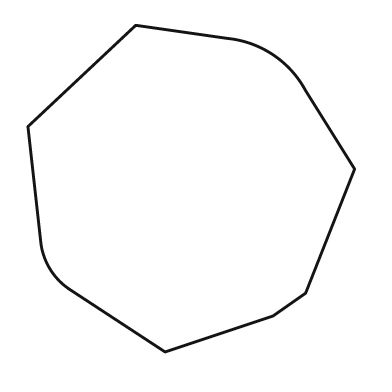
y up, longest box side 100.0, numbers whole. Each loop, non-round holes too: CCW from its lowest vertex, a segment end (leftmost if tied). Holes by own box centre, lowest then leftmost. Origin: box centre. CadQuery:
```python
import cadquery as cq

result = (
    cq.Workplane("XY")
    .moveTo(-8.0, -50.0)
    .lineTo(25.0, -39.0)
    .lineTo(35.0, -32.0)
    .lineTo(50.0, 6.0)
    .lineTo(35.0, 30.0)
    .threePointArc((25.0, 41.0), (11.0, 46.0))
    .lineTo(-17.0, 50.0)
    .lineTo(-50.0, 19.0)
    .lineTo(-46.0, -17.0)
    .threePointArc((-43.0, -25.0), (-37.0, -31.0))
    .close()
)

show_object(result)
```